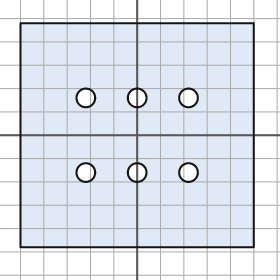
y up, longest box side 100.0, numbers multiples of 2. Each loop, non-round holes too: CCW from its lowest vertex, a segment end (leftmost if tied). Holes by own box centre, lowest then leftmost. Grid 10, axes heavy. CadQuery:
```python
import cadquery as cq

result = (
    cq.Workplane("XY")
    .moveTo(-50.0, -48.0)
    .lineTo(50.0, -48.0)
    .lineTo(50.0, 48.0)
    .lineTo(-50.0, 48.0)
    .close()
    .moveTo(-22.0, -16.0)
    .circle(4.0)
    .moveTo(0.0, -16.0)
    .circle(4.0)
    .moveTo(22.0, -16.0)
    .circle(4.0)
    .moveTo(-22.0, 16.0)
    .circle(4.0)
    .moveTo(0.0, 16.0)
    .circle(4.0)
    .moveTo(22.0, 16.0)
    .circle(4.0)
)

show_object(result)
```